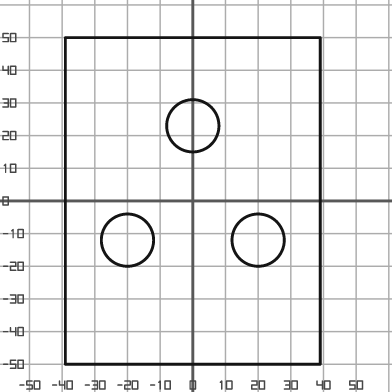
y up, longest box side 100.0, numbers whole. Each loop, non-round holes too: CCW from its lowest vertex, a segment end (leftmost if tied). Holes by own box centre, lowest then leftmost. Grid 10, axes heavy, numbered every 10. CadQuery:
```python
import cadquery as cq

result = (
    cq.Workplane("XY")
    .moveTo(-39.0, -50.0)
    .lineTo(39.0, -50.0)
    .lineTo(39.0, 50.0)
    .lineTo(-39.0, 50.0)
    .close()
    .moveTo(-20.0, -12.0)
    .circle(8.0)
    .moveTo(20.0, -12.0)
    .circle(8.0)
    .moveTo(0.0, 23.0)
    .circle(8.0)
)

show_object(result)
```